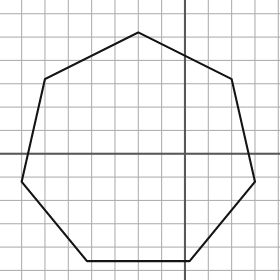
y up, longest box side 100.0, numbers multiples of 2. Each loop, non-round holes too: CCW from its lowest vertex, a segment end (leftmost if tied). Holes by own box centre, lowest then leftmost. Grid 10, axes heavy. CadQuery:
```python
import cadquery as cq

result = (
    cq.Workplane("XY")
    .moveTo(-42.0, -46.0)
    .lineTo(2.0, -46.0)
    .lineTo(30.0, -12.0)
    .lineTo(20.0, 32.0)
    .lineTo(-20.0, 52.0)
    .lineTo(-60.0, 32.0)
    .lineTo(-70.0, -12.0)
    .close()
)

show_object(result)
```